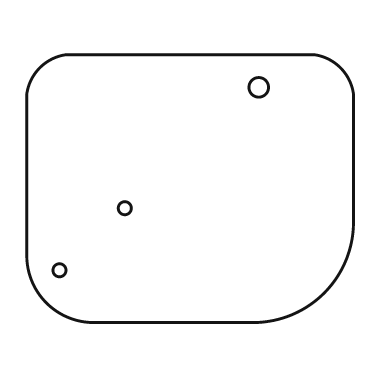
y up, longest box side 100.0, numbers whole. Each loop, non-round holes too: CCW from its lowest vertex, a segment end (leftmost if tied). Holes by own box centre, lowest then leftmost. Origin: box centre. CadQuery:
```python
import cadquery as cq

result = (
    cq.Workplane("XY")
    .moveTo(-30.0, -41.0)
    .lineTo(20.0, -41.0)
    .threePointArc((41.0, -32.0), (50.0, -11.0))
    .lineTo(50.0, 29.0)
    .threePointArc((46.0, 37.0), (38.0, 41.0))
    .lineTo(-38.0, 41.0)
    .threePointArc((-46.0, 37.0), (-50.0, 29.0))
    .lineTo(-50.0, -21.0)
    .threePointArc((-44.0, -35.0), (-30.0, -41.0))
    .close()
    .moveTo(-40.0, -25.0)
    .circle(2.0)
    .moveTo(-20.0, -6.0)
    .circle(2.0)
    .moveTo(21.0, 31.0)
    .circle(3.0)
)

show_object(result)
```